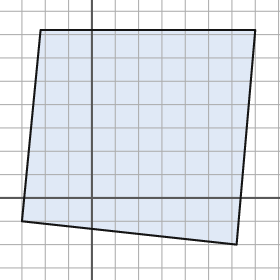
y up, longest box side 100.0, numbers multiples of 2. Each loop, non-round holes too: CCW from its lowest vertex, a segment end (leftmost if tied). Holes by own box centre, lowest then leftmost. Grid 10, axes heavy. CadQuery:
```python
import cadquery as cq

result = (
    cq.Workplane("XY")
    .moveTo(62.0, -20.0)
    .lineTo(70.0, 72.0)
    .lineTo(-22.0, 72.0)
    .lineTo(-30.0, -10.0)
    .close()
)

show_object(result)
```